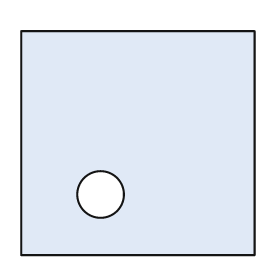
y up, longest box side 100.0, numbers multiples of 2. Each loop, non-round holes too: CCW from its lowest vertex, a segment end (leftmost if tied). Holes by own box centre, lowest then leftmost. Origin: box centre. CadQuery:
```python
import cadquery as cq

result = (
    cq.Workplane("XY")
    .moveTo(-50.0, -48.0)
    .lineTo(50.0, -48.0)
    .lineTo(50.0, 48.0)
    .lineTo(-50.0, 48.0)
    .close()
    .moveTo(-16.0, -22.0)
    .circle(10.0)
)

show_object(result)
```